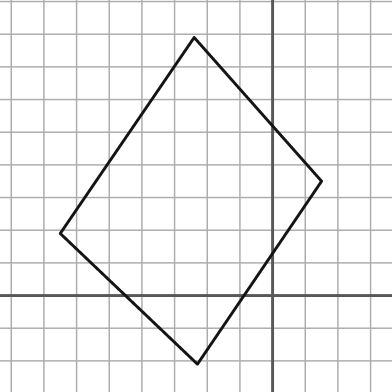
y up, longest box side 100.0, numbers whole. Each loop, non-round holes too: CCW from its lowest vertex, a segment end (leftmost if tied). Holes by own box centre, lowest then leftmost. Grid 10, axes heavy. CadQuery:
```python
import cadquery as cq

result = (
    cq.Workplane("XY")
    .moveTo(-23.0, -21.0)
    .lineTo(15.0, 35.0)
    .lineTo(-24.0, 79.0)
    .lineTo(-65.0, 19.0)
    .close()
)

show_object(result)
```